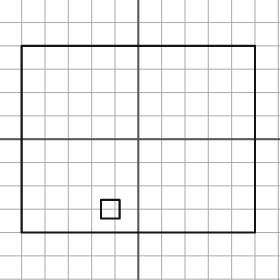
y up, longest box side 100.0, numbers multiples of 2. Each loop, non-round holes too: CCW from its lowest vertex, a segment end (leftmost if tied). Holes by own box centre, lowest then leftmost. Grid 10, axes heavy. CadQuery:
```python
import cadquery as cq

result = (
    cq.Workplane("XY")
    .moveTo(-50.0, -40.0)
    .lineTo(50.0, -40.0)
    .lineTo(50.0, 40.0)
    .lineTo(-50.0, 40.0)
    .close()
    .moveTo(-16.0, -34.0)
    .lineTo(-8.0, -34.0)
    .lineTo(-8.0, -26.0)
    .lineTo(-16.0, -26.0)
    .close()
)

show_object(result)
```